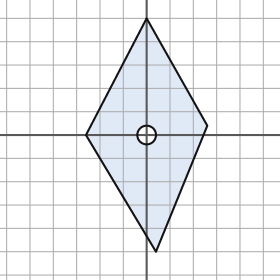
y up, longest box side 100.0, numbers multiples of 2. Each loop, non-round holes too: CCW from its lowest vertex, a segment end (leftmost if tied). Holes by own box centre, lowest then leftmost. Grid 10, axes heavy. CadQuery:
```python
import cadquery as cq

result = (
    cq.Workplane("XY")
    .moveTo(4.0, -50.0)
    .lineTo(26.0, 4.0)
    .lineTo(0.0, 50.0)
    .lineTo(-26.0, 0.0)
    .close()
    .moveTo(0.0, 0.0)
    .circle(4.0)
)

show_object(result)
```